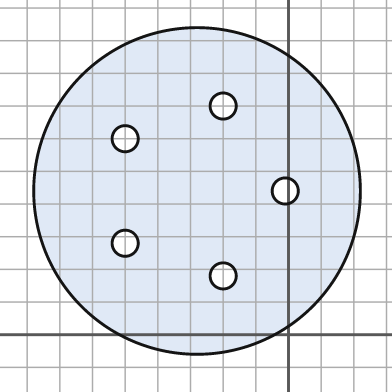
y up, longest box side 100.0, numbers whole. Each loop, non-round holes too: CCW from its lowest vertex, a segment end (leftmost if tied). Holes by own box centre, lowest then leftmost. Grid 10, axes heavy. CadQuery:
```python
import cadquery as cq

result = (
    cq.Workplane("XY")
    .moveTo(-28.0, 44.0)
    .circle(50.0)
    .moveTo(-20.0, 18.0)
    .circle(4.0)
    .moveTo(-50.0, 28.0)
    .circle(4.0)
    .moveTo(-1.0, 44.0)
    .circle(4.0)
    .moveTo(-50.0, 60.0)
    .circle(4.0)
    .moveTo(-20.0, 70.0)
    .circle(4.0)
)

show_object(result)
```